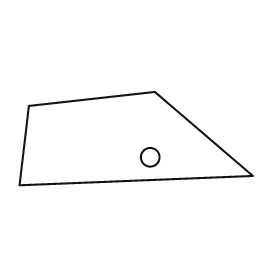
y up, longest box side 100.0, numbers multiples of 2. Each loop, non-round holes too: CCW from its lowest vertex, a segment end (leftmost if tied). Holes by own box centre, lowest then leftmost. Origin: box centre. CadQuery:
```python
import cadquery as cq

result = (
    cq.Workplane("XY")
    .moveTo(-50.0, -20.0)
    .lineTo(50.0, -16.0)
    .lineTo(8.0, 20.0)
    .lineTo(-46.0, 14.0)
    .close()
    .moveTo(6.0, -8.0)
    .circle(4.0)
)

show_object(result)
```